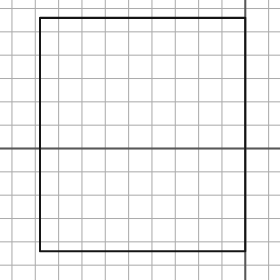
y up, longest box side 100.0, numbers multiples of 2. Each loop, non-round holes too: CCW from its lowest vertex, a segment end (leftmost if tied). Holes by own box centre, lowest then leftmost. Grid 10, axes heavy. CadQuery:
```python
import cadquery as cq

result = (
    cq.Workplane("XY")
    .moveTo(-88.0, -44.0)
    .lineTo(0.0, -44.0)
    .lineTo(0.0, 56.0)
    .lineTo(-88.0, 56.0)
    .close()
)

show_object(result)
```